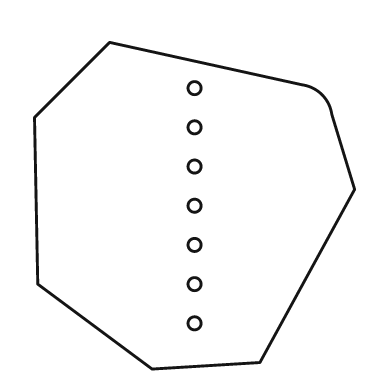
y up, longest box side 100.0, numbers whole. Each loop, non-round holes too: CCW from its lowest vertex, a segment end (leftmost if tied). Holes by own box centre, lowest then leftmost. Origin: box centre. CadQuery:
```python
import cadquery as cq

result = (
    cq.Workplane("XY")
    .moveTo(-13.0, -50.0)
    .lineTo(20.0, -48.0)
    .lineTo(49.0, 5.0)
    .lineTo(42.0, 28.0)
    .threePointArc((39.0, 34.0), (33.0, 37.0))
    .lineTo(-26.0, 50.0)
    .lineTo(-49.0, 27.0)
    .lineTo(-48.0, -24.0)
    .close()
    .moveTo(0.0, -36.0)
    .circle(2.0)
    .moveTo(0.0, -24.0)
    .circle(2.0)
    .moveTo(0.0, -12.0)
    .circle(2.0)
    .moveTo(0.0, 0.0)
    .circle(2.0)
    .moveTo(0.0, 12.0)
    .circle(2.0)
    .moveTo(0.0, 24.0)
    .circle(2.0)
    .moveTo(0.0, 36.0)
    .circle(2.0)
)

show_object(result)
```